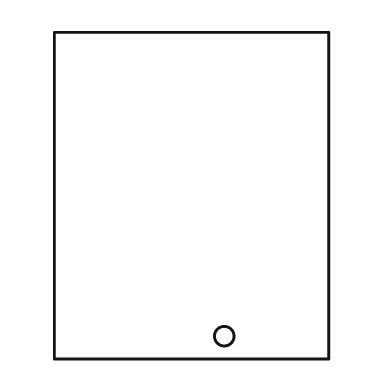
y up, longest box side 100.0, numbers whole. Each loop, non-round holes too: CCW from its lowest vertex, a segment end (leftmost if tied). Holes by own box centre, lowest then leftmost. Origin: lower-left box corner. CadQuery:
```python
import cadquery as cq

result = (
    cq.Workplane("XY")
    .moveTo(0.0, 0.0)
    .lineTo(84.0, 0.0)
    .lineTo(84.0, 100.0)
    .lineTo(0.0, 100.0)
    .close()
    .moveTo(52.0, 7.0)
    .circle(3.0)
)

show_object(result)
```